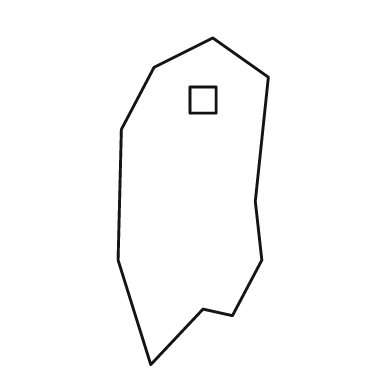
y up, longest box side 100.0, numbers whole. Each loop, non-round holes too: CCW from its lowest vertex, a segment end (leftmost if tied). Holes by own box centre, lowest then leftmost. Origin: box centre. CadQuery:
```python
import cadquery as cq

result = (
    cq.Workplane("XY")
    .moveTo(-13.0, -50.0)
    .lineTo(3.0, -33.0)
    .lineTo(12.0, -35.0)
    .lineTo(21.0, -18.0)
    .lineTo(19.0, 0.0)
    .lineTo(23.0, 38.0)
    .lineTo(6.0, 50.0)
    .lineTo(-12.0, 41.0)
    .lineTo(-22.0, 22.0)
    .lineTo(-23.0, -18.0)
    .close()
    .moveTo(-1.0, 27.0)
    .lineTo(7.0, 27.0)
    .lineTo(7.0, 35.0)
    .lineTo(-1.0, 35.0)
    .close()
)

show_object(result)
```